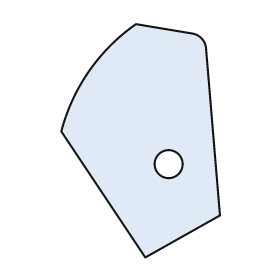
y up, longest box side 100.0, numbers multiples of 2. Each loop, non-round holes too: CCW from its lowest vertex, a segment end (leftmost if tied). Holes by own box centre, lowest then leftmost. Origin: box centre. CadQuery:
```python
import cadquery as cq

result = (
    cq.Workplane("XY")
    .moveTo(2.0, -50.0)
    .lineTo(34.0, -32.0)
    .lineTo(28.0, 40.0)
    .threePointArc((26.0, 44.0), (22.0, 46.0))
    .lineTo(-2.0, 50.0)
    .threePointArc((-22.0, 30.0), (-34.0, 4.0))
    .close()
    .moveTo(12.0, -10.0)
    .circle(6.0)
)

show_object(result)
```